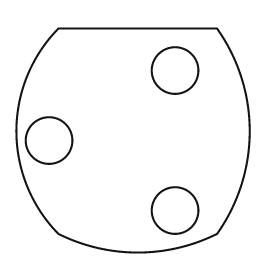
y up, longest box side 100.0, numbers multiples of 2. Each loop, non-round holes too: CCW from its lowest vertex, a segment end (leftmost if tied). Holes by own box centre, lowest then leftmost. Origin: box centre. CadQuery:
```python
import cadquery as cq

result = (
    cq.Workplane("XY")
    .moveTo(-32.0, -40.0)
    .threePointArc((2.0, -48.0), (36.0, -40.0))
    .threePointArc((50.0, 4.0), (36.0, 48.0))
    .lineTo(-32.0, 48.0)
    .threePointArc((-50.0, 4.0), (-32.0, -40.0))
    .close()
    .moveTo(18.0, -30.0)
    .circle(10.0)
    .moveTo(-36.0, 0.0)
    .circle(10.0)
    .moveTo(18.0, 30.0)
    .circle(10.0)
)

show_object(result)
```